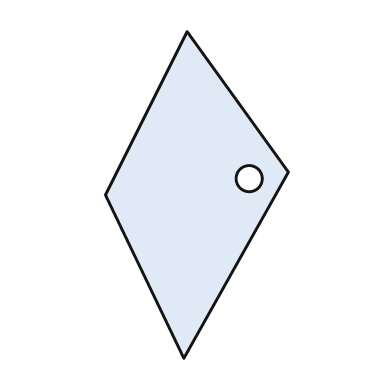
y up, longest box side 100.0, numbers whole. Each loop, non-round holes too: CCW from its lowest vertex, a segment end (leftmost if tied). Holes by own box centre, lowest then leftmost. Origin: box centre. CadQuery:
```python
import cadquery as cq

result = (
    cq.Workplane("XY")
    .moveTo(-4.0, -50.0)
    .lineTo(28.0, 7.0)
    .lineTo(-3.0, 50.0)
    .lineTo(-28.0, 0.0)
    .close()
    .moveTo(16.0, 5.0)
    .circle(4.0)
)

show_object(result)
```